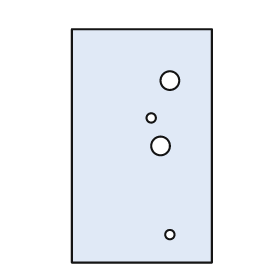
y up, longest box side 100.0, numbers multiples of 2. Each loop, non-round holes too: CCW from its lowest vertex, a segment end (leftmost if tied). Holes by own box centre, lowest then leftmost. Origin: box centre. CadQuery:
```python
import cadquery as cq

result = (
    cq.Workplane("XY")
    .moveTo(-30.0, -50.0)
    .lineTo(30.0, -50.0)
    .lineTo(30.0, 50.0)
    .lineTo(-30.0, 50.0)
    .close()
    .moveTo(12.0, -38.0)
    .circle(2.0)
    .moveTo(8.0, 0.0)
    .circle(4.0)
    .moveTo(4.0, 12.0)
    .circle(2.0)
    .moveTo(12.0, 28.0)
    .circle(4.0)
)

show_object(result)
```